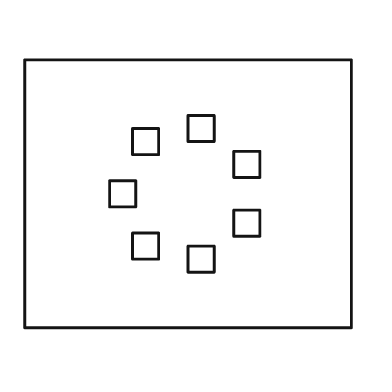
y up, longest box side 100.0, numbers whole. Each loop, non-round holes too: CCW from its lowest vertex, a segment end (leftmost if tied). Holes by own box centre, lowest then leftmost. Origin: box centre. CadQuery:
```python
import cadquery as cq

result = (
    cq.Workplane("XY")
    .moveTo(-50.0, -41.0)
    .lineTo(50.0, -41.0)
    .lineTo(50.0, 41.0)
    .lineTo(-50.0, 41.0)
    .close()
    .moveTo(0.0, -24.0)
    .lineTo(8.0, -24.0)
    .lineTo(8.0, -16.0)
    .lineTo(0.0, -16.0)
    .close()
    .moveTo(-17.0, -20.0)
    .lineTo(-9.0, -20.0)
    .lineTo(-9.0, -12.0)
    .lineTo(-17.0, -12.0)
    .close()
    .moveTo(14.0, -13.0)
    .lineTo(22.0, -13.0)
    .lineTo(22.0, -5.0)
    .lineTo(14.0, -5.0)
    .close()
    .moveTo(-24.0, -4.0)
    .lineTo(-16.0, -4.0)
    .lineTo(-16.0, 4.0)
    .lineTo(-24.0, 4.0)
    .close()
    .moveTo(14.0, 5.0)
    .lineTo(22.0, 5.0)
    .lineTo(22.0, 13.0)
    .lineTo(14.0, 13.0)
    .close()
    .moveTo(-17.0, 12.0)
    .lineTo(-9.0, 12.0)
    .lineTo(-9.0, 20.0)
    .lineTo(-17.0, 20.0)
    .close()
    .moveTo(0.0, 16.0)
    .lineTo(8.0, 16.0)
    .lineTo(8.0, 24.0)
    .lineTo(0.0, 24.0)
    .close()
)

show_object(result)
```